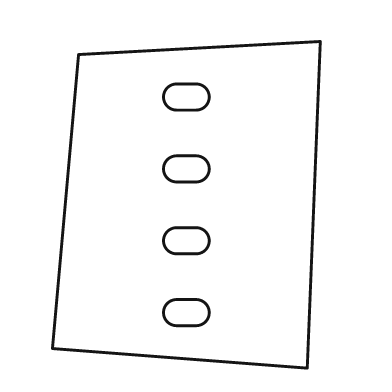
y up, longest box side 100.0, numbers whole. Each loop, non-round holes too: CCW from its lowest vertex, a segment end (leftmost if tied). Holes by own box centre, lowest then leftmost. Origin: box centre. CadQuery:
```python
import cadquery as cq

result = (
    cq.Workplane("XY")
    .moveTo(37.0, -50.0)
    .lineTo(41.0, 50.0)
    .lineTo(-33.0, 46.0)
    .lineTo(-41.0, -44.0)
    .close()
    .moveTo(-3.0, -37.0)
    .lineTo(3.0, -37.0)
    .threePointArc((7.0, -33.0), (3.0, -29.0))
    .lineTo(-3.0, -29.0)
    .threePointArc((-7.0, -33.0), (-3.0, -37.0))
    .close()
    .moveTo(-3.0, -15.0)
    .lineTo(3.0, -15.0)
    .threePointArc((7.0, -11.0), (3.0, -7.0))
    .lineTo(-3.0, -7.0)
    .threePointArc((-7.0, -11.0), (-3.0, -15.0))
    .close()
    .moveTo(-3.0, 7.0)
    .lineTo(3.0, 7.0)
    .threePointArc((7.0, 11.0), (3.0, 15.0))
    .lineTo(-3.0, 15.0)
    .threePointArc((-7.0, 11.0), (-3.0, 7.0))
    .close()
    .moveTo(-3.0, 29.0)
    .lineTo(3.0, 29.0)
    .threePointArc((7.0, 33.0), (3.0, 37.0))
    .lineTo(-3.0, 37.0)
    .threePointArc((-7.0, 33.0), (-3.0, 29.0))
    .close()
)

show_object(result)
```